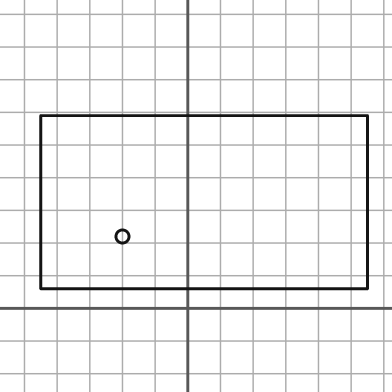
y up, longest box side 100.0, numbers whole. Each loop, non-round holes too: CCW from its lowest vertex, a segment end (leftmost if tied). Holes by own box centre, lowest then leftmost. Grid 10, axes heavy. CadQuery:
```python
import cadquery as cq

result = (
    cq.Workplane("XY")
    .moveTo(-45.0, 6.0)
    .lineTo(55.0, 6.0)
    .lineTo(55.0, 59.0)
    .lineTo(-45.0, 59.0)
    .close()
    .moveTo(-20.0, 22.0)
    .circle(2.0)
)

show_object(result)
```